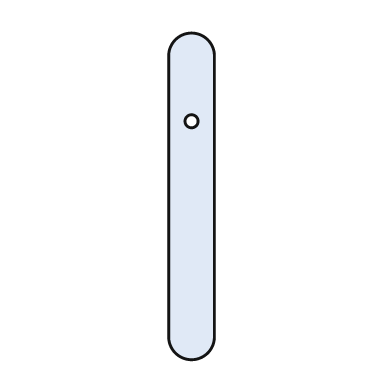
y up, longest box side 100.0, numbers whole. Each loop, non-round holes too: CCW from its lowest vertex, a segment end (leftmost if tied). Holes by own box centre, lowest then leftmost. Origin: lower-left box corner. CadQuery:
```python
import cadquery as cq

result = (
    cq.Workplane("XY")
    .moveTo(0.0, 7.0)
    .threePointArc((7.0, 0.0), (14.0, 7.0))
    .lineTo(14.0, 93.0)
    .threePointArc((7.0, 100.0), (0.0, 93.0))
    .close()
    .moveTo(7.0, 73.0)
    .circle(2.0)
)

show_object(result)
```